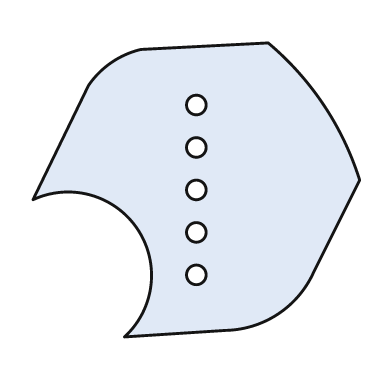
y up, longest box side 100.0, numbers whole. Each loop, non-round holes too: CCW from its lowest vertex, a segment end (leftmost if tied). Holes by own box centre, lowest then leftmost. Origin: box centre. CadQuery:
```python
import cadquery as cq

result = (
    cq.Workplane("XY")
    .moveTo(-22.0, -45.0)
    .lineTo(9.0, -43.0)
    .threePointArc((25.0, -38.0), (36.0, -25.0))
    .lineTo(50.0, 3.0)
    .threePointArc((39.0, 26.0), (22.0, 45.0))
    .lineTo(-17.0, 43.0)
    .threePointArc((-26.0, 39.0), (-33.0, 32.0))
    .lineTo(-50.0, -3.0)
    .threePointArc((-18.0, -12.0), (-22.0, -45.0))
    .close()
    .moveTo(0.0, -26.0)
    .circle(3.0)
    .moveTo(0.0, -13.0)
    .circle(3.0)
    .moveTo(0.0, 0.0)
    .circle(3.0)
    .moveTo(0.0, 13.0)
    .circle(3.0)
    .moveTo(0.0, 26.0)
    .circle(3.0)
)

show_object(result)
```